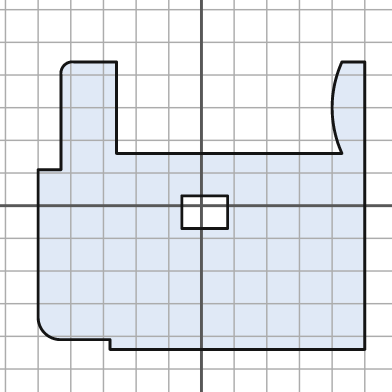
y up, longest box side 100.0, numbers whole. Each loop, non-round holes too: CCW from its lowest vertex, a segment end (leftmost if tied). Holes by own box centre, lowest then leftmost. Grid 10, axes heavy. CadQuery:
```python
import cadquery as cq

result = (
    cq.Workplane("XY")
    .moveTo(-28.0, -44.0)
    .lineTo(50.0, -44.0)
    .lineTo(50.0, 44.0)
    .lineTo(43.0, 44.0)
    .threePointArc((40.0, 30.0), (43.0, 16.0))
    .lineTo(-26.0, 16.0)
    .lineTo(-26.0, 44.0)
    .lineTo(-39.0, 44.0)
    .threePointArc((-42.0, 43.0), (-43.0, 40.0))
    .lineTo(-43.0, 11.0)
    .lineTo(-50.0, 11.0)
    .lineTo(-50.0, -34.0)
    .threePointArc((-48.0, -39.0), (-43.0, -41.0))
    .lineTo(-28.0, -41.0)
    .close()
    .moveTo(-6.0, -7.0)
    .lineTo(8.0, -7.0)
    .lineTo(8.0, 3.0)
    .lineTo(-6.0, 3.0)
    .close()
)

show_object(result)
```